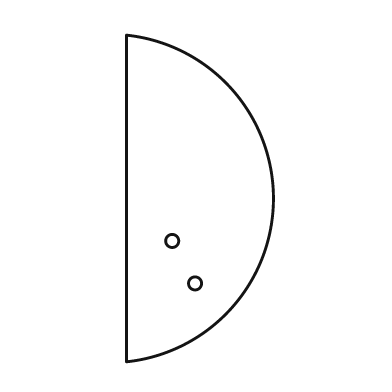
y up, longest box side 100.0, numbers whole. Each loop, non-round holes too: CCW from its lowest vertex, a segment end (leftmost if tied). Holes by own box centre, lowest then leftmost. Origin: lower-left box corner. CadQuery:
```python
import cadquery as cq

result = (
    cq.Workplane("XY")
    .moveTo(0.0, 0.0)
    .threePointArc((45.0, 50.0), (0.0, 100.0))
    .close()
    .moveTo(21.0, 24.0)
    .circle(2.0)
    .moveTo(14.0, 37.0)
    .circle(2.0)
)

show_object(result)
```